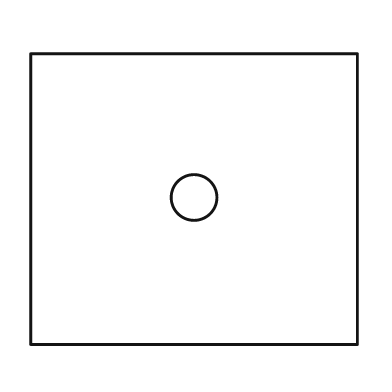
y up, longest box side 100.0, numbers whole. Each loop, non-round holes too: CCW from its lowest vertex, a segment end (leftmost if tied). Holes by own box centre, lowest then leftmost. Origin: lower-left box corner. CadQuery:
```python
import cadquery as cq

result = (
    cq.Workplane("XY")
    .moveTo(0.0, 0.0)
    .lineTo(100.0, 0.0)
    .lineTo(100.0, 89.0)
    .lineTo(0.0, 89.0)
    .close()
    .moveTo(50.0, 45.0)
    .circle(7.0)
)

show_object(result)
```